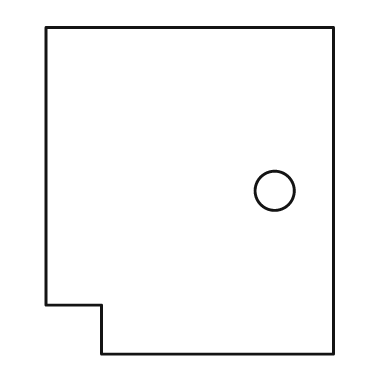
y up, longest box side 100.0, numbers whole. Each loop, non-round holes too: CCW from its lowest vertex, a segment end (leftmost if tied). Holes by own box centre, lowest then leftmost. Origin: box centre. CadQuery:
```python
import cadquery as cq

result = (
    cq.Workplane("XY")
    .moveTo(-27.0, -50.0)
    .lineTo(44.0, -50.0)
    .lineTo(44.0, 50.0)
    .lineTo(-44.0, 50.0)
    .lineTo(-44.0, -35.0)
    .lineTo(-27.0, -35.0)
    .close()
    .moveTo(26.0, 0.0)
    .circle(6.0)
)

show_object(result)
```